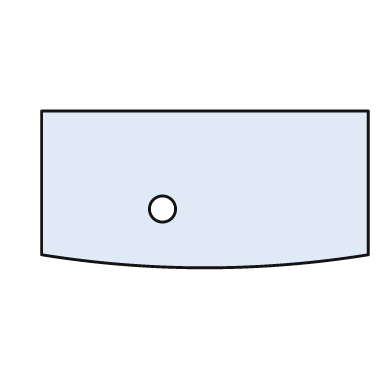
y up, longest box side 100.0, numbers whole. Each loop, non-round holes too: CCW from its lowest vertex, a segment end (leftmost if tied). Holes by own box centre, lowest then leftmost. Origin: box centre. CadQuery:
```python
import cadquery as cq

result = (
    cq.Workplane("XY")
    .moveTo(-50.0, -20.0)
    .threePointArc((0.0, -24.0), (50.0, -20.0))
    .lineTo(50.0, 24.0)
    .lineTo(-50.0, 24.0)
    .close()
    .moveTo(-13.0, -6.0)
    .circle(4.0)
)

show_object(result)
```